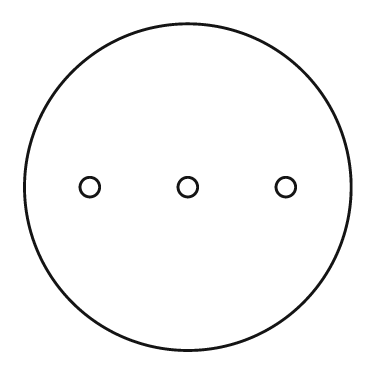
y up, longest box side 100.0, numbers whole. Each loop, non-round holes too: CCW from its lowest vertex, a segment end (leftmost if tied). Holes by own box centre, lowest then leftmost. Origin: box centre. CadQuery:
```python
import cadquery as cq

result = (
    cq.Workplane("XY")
    .moveTo(0.0, 0.0)
    .circle(50.0)
    .moveTo(-30.0, 0.0)
    .circle(3.0)
    .moveTo(0.0, 0.0)
    .circle(3.0)
    .moveTo(30.0, 0.0)
    .circle(3.0)
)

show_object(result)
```